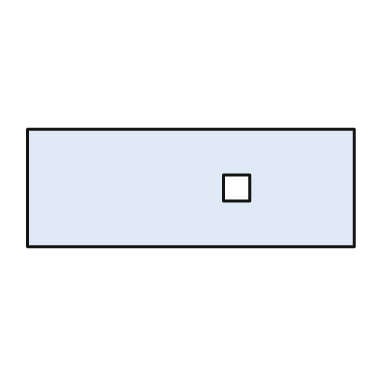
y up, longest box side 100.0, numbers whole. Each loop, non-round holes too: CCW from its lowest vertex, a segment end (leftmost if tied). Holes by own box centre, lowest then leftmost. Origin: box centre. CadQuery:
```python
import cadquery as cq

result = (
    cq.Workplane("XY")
    .moveTo(-50.0, -18.0)
    .lineTo(50.0, -18.0)
    .lineTo(50.0, 18.0)
    .lineTo(-50.0, 18.0)
    .close()
    .moveTo(10.0, -4.0)
    .lineTo(18.0, -4.0)
    .lineTo(18.0, 4.0)
    .lineTo(10.0, 4.0)
    .close()
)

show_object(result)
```